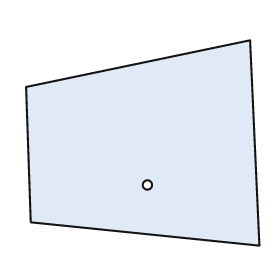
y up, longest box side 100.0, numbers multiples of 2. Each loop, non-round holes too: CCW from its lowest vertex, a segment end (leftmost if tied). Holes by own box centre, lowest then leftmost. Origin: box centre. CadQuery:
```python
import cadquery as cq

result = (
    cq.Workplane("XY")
    .moveTo(50.0, -44.0)
    .lineTo(46.0, 44.0)
    .lineTo(-50.0, 24.0)
    .lineTo(-48.0, -34.0)
    .close()
    .moveTo(2.0, -18.0)
    .circle(2.0)
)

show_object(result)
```